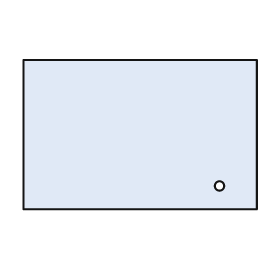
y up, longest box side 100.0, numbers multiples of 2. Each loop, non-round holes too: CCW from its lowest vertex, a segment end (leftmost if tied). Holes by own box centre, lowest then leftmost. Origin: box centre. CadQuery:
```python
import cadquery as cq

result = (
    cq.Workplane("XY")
    .moveTo(-50.0, -32.0)
    .lineTo(50.0, -32.0)
    .lineTo(50.0, 32.0)
    .lineTo(-50.0, 32.0)
    .close()
    .moveTo(34.0, -22.0)
    .circle(2.0)
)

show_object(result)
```